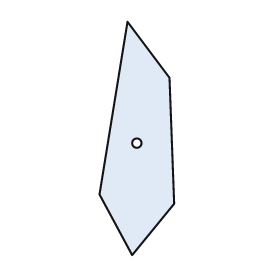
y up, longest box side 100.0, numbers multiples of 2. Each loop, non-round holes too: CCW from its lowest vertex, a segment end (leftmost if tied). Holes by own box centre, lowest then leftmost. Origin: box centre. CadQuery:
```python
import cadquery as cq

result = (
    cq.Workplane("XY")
    .moveTo(-2.0, -50.0)
    .lineTo(16.0, -28.0)
    .lineTo(14.0, 26.0)
    .lineTo(-4.0, 50.0)
    .lineTo(-16.0, -24.0)
    .close()
    .moveTo(0.0, -2.0)
    .circle(2.0)
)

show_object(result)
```